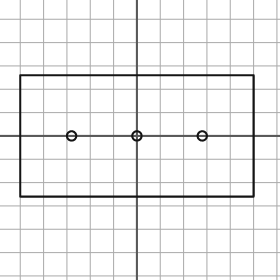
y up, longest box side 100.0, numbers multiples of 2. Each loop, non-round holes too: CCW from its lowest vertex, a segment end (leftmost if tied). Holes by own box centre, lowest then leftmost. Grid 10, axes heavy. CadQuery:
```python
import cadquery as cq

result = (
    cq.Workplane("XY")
    .moveTo(-50.0, -26.0)
    .lineTo(50.0, -26.0)
    .lineTo(50.0, 26.0)
    .lineTo(-50.0, 26.0)
    .close()
    .moveTo(-28.0, 0.0)
    .circle(2.0)
    .moveTo(0.0, 0.0)
    .circle(2.0)
    .moveTo(28.0, 0.0)
    .circle(2.0)
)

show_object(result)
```